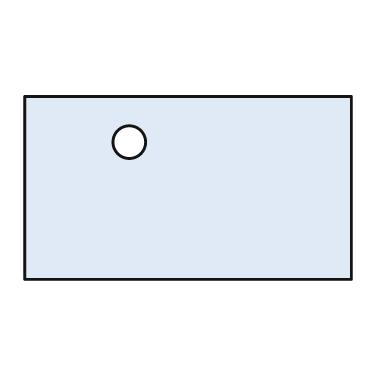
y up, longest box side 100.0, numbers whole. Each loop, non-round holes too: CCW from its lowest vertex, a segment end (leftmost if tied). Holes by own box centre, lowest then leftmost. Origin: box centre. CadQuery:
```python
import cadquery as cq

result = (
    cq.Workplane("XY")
    .moveTo(-50.0, -28.0)
    .lineTo(50.0, -28.0)
    .lineTo(50.0, 28.0)
    .lineTo(-50.0, 28.0)
    .close()
    .moveTo(-18.0, 14.0)
    .circle(5.0)
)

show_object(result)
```